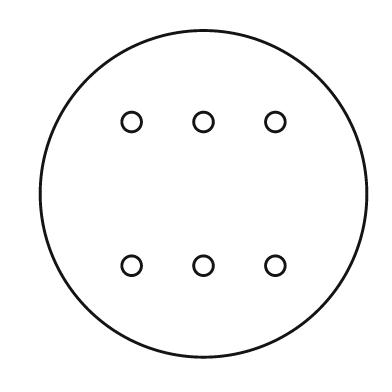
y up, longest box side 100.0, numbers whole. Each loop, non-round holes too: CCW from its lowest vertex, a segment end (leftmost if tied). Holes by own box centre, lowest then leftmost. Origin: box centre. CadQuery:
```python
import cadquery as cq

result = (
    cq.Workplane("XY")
    .moveTo(0.0, 0.0)
    .circle(50.0)
    .moveTo(-22.0, -22.0)
    .circle(3.0)
    .moveTo(0.0, -22.0)
    .circle(3.0)
    .moveTo(22.0, -22.0)
    .circle(3.0)
    .moveTo(-22.0, 22.0)
    .circle(3.0)
    .moveTo(0.0, 22.0)
    .circle(3.0)
    .moveTo(22.0, 22.0)
    .circle(3.0)
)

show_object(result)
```